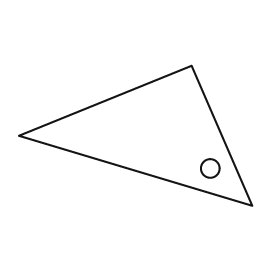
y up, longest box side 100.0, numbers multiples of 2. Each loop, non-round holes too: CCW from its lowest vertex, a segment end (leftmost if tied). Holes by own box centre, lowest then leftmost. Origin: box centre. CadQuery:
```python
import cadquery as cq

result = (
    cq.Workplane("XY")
    .moveTo(50.0, -30.0)
    .lineTo(24.0, 30.0)
    .lineTo(-50.0, 0.0)
    .close()
    .moveTo(32.0, -14.0)
    .circle(4.0)
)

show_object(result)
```